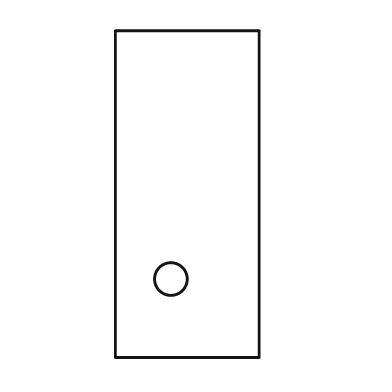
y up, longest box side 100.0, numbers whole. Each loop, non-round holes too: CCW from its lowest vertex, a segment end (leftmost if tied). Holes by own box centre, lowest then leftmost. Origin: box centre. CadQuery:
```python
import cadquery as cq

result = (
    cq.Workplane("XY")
    .moveTo(-22.0, -50.0)
    .lineTo(22.0, -50.0)
    .lineTo(22.0, 50.0)
    .lineTo(-22.0, 50.0)
    .close()
    .moveTo(-5.0, -26.0)
    .circle(5.0)
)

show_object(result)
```